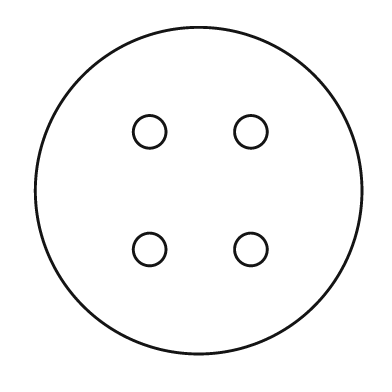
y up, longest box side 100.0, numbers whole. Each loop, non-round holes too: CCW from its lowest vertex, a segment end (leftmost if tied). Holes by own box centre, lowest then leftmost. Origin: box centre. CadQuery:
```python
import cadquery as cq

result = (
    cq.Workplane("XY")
    .moveTo(0.0, 0.0)
    .circle(50.0)
    .moveTo(-15.0, -18.0)
    .circle(5.0)
    .moveTo(16.0, -18.0)
    .circle(5.0)
    .moveTo(-15.0, 18.0)
    .circle(5.0)
    .moveTo(16.0, 18.0)
    .circle(5.0)
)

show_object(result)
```